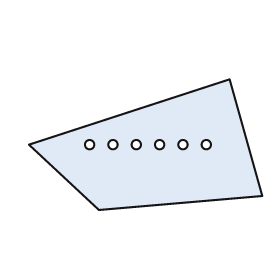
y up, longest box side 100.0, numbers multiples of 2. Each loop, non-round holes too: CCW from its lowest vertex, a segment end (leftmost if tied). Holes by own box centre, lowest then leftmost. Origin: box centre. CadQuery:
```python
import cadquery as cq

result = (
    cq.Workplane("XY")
    .moveTo(-20.0, -28.0)
    .lineTo(50.0, -22.0)
    .lineTo(36.0, 28.0)
    .lineTo(-50.0, 0.0)
    .close()
    .moveTo(-24.0, 0.0)
    .circle(2.0)
    .moveTo(-14.0, 0.0)
    .circle(2.0)
    .moveTo(-4.0, 0.0)
    .circle(2.0)
    .moveTo(6.0, 0.0)
    .circle(2.0)
    .moveTo(16.0, 0.0)
    .circle(2.0)
    .moveTo(26.0, 0.0)
    .circle(2.0)
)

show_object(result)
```